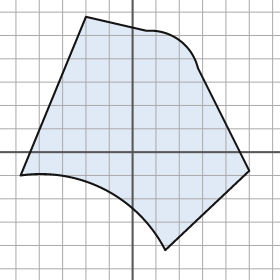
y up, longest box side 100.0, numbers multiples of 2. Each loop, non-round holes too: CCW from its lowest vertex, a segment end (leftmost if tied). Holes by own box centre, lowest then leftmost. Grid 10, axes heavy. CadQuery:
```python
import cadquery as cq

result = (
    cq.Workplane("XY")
    .moveTo(14.0, -42.0)
    .lineTo(50.0, -8.0)
    .lineTo(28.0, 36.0)
    .threePointArc((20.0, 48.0), (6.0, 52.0))
    .lineTo(-20.0, 58.0)
    .lineTo(-48.0, -10.0)
    .threePointArc((-12.0, -16.0), (14.0, -42.0))
    .close()
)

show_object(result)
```